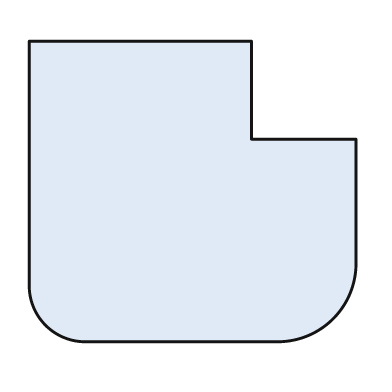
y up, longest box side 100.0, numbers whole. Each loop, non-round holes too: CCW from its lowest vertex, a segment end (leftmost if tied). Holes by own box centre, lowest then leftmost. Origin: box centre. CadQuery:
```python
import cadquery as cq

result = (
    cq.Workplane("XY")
    .moveTo(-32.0, -46.0)
    .lineTo(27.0, -46.0)
    .threePointArc((43.0, -39.0), (50.0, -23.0))
    .lineTo(50.0, 16.0)
    .lineTo(18.0, 16.0)
    .lineTo(18.0, 46.0)
    .lineTo(-50.0, 46.0)
    .lineTo(-50.0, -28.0)
    .threePointArc((-45.0, -41.0), (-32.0, -46.0))
    .close()
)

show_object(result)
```